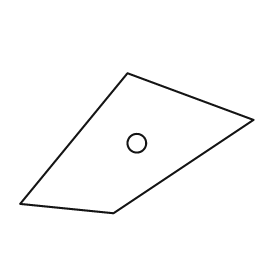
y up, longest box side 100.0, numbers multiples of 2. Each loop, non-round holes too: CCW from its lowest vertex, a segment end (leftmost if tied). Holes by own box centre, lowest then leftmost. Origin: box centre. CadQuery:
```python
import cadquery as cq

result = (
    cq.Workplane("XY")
    .moveTo(-10.0, -30.0)
    .lineTo(50.0, 10.0)
    .lineTo(-4.0, 30.0)
    .lineTo(-50.0, -26.0)
    .close()
    .moveTo(0.0, 0.0)
    .circle(4.0)
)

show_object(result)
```